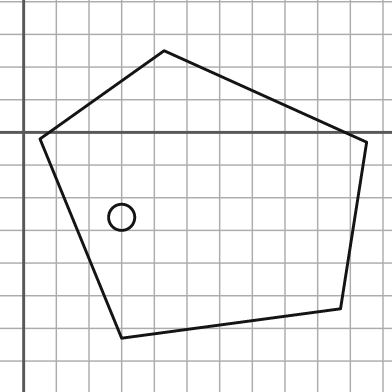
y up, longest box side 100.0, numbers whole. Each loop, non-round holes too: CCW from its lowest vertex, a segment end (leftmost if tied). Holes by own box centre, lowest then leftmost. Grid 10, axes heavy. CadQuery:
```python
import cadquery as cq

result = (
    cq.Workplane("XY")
    .moveTo(30.0, -63.0)
    .lineTo(97.0, -54.0)
    .lineTo(105.0, -3.0)
    .lineTo(43.0, 25.0)
    .lineTo(5.0, -2.0)
    .close()
    .moveTo(30.0, -26.0)
    .circle(4.0)
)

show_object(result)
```